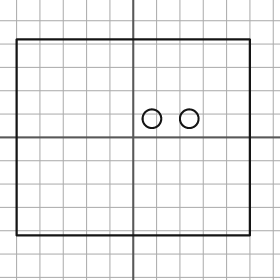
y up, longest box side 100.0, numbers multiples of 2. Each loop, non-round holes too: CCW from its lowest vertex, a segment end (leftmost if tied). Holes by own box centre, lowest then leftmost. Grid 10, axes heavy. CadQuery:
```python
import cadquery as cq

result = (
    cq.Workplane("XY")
    .moveTo(-50.0, -42.0)
    .lineTo(50.0, -42.0)
    .lineTo(50.0, 42.0)
    .lineTo(-50.0, 42.0)
    .close()
    .moveTo(8.0, 8.0)
    .circle(4.0)
    .moveTo(24.0, 8.0)
    .circle(4.0)
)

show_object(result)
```